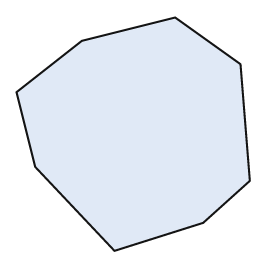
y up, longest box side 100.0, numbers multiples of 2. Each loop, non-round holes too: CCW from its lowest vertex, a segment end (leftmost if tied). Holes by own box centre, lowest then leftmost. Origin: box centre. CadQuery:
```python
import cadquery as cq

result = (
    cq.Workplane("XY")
    .moveTo(-8.0, -50.0)
    .lineTo(30.0, -38.0)
    .lineTo(50.0, -20.0)
    .lineTo(46.0, 30.0)
    .lineTo(18.0, 50.0)
    .lineTo(-22.0, 40.0)
    .lineTo(-50.0, 18.0)
    .lineTo(-42.0, -14.0)
    .close()
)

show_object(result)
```